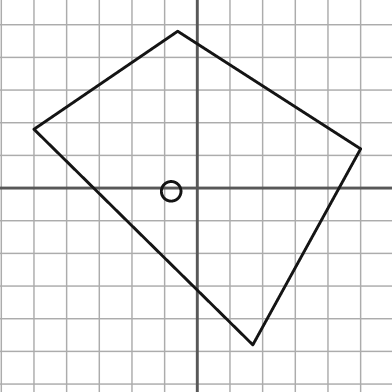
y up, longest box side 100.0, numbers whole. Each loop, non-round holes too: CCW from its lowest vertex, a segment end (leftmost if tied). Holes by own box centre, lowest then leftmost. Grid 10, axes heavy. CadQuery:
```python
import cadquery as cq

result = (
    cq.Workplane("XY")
    .moveTo(17.0, -48.0)
    .lineTo(50.0, 12.0)
    .lineTo(-6.0, 48.0)
    .lineTo(-50.0, 18.0)
    .close()
    .moveTo(-8.0, -1.0)
    .circle(3.0)
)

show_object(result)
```